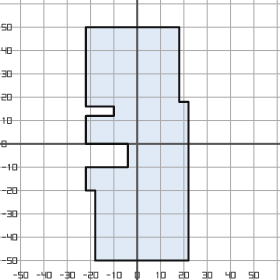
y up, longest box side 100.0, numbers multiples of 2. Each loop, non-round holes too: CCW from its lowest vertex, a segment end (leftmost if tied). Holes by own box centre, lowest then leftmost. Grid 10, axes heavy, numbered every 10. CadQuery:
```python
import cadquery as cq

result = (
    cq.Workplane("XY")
    .moveTo(-18.0, -50.0)
    .lineTo(22.0, -50.0)
    .lineTo(22.0, 18.0)
    .lineTo(18.0, 18.0)
    .lineTo(18.0, 50.0)
    .lineTo(-22.0, 50.0)
    .lineTo(-22.0, 16.0)
    .lineTo(-10.0, 16.0)
    .lineTo(-10.0, 12.0)
    .lineTo(-22.0, 12.0)
    .lineTo(-22.0, 0.0)
    .lineTo(-4.0, 0.0)
    .lineTo(-4.0, -10.0)
    .lineTo(-22.0, -10.0)
    .lineTo(-22.0, -20.0)
    .lineTo(-18.0, -20.0)
    .close()
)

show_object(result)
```